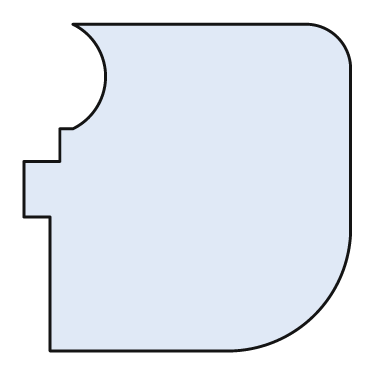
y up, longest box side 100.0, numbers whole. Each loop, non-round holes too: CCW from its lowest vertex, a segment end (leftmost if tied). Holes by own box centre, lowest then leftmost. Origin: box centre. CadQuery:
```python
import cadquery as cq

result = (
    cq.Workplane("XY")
    .moveTo(-42.0, -50.0)
    .lineTo(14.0, -50.0)
    .threePointArc((39.0, -39.0), (50.0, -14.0))
    .lineTo(50.0, 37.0)
    .threePointArc((46.0, 46.0), (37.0, 50.0))
    .lineTo(-35.0, 50.0)
    .threePointArc((-25.0, 34.0), (-35.0, 18.0))
    .lineTo(-39.0, 18.0)
    .lineTo(-39.0, 8.0)
    .lineTo(-50.0, 8.0)
    .lineTo(-50.0, -9.0)
    .lineTo(-42.0, -9.0)
    .close()
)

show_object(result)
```